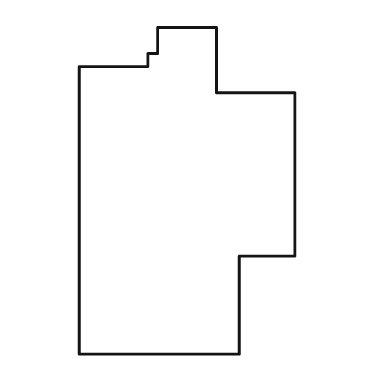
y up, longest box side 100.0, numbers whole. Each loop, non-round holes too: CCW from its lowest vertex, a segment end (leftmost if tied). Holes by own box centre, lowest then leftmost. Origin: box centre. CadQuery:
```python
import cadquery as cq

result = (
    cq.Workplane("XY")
    .moveTo(-33.0, -50.0)
    .lineTo(16.0, -50.0)
    .lineTo(16.0, -20.0)
    .lineTo(33.0, -20.0)
    .lineTo(33.0, 30.0)
    .lineTo(9.0, 30.0)
    .lineTo(9.0, 50.0)
    .lineTo(-9.0, 50.0)
    .lineTo(-9.0, 42.0)
    .lineTo(-12.0, 42.0)
    .lineTo(-12.0, 38.0)
    .lineTo(-33.0, 38.0)
    .close()
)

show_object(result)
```